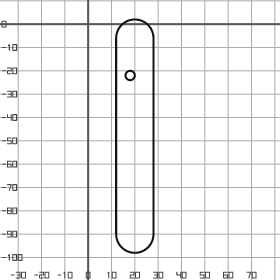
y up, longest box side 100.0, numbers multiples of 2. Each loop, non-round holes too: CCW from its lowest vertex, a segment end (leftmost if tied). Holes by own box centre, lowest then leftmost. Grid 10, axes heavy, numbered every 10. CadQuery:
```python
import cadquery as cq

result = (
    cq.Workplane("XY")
    .moveTo(12.0, -90.0)
    .threePointArc((20.0, -98.0), (28.0, -90.0))
    .lineTo(28.0, -6.0)
    .threePointArc((20.0, 2.0), (12.0, -6.0))
    .close()
    .moveTo(18.0, -22.0)
    .circle(2.0)
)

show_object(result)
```